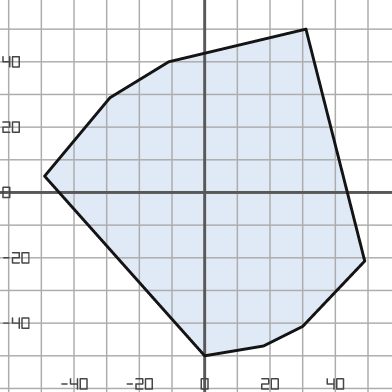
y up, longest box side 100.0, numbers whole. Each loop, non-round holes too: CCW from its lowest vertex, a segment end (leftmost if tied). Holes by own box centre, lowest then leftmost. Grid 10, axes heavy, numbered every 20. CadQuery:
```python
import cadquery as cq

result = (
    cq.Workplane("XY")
    .moveTo(0.0, -50.0)
    .lineTo(18.0, -47.0)
    .lineTo(30.0, -41.0)
    .lineTo(49.0, -21.0)
    .lineTo(31.0, 50.0)
    .lineTo(-11.0, 40.0)
    .lineTo(-29.0, 29.0)
    .lineTo(-49.0, 5.0)
    .close()
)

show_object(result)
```